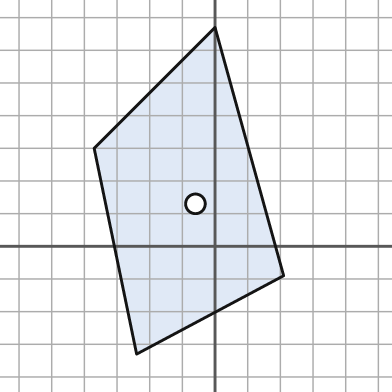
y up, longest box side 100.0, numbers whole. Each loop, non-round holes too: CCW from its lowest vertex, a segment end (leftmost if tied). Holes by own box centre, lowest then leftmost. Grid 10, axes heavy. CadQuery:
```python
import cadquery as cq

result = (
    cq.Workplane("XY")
    .moveTo(-24.0, -33.0)
    .lineTo(21.0, -9.0)
    .lineTo(0.0, 67.0)
    .lineTo(-37.0, 30.0)
    .close()
    .moveTo(-6.0, 13.0)
    .circle(3.0)
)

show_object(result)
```